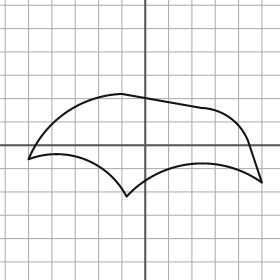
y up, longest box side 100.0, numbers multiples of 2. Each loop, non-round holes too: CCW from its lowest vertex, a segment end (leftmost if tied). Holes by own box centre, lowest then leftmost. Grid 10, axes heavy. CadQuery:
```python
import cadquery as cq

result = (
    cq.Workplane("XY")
    .moveTo(-8.0, -22.0)
    .threePointArc((20.0, -8.0), (50.0, -16.0))
    .lineTo(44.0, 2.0)
    .threePointArc((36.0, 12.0), (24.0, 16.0))
    .lineTo(-10.0, 22.0)
    .threePointArc((-34.0, 14.0), (-50.0, -6.0))
    .threePointArc((-26.0, -6.0), (-8.0, -22.0))
    .close()
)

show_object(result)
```